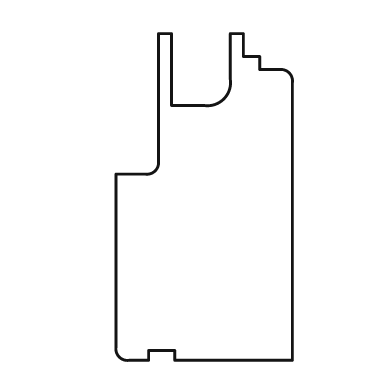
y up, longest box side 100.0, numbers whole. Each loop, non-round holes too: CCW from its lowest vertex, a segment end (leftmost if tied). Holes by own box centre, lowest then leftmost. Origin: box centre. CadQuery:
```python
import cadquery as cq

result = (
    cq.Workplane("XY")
    .moveTo(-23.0, -50.0)
    .lineTo(-17.0, -50.0)
    .lineTo(-17.0, -47.0)
    .lineTo(-9.0, -47.0)
    .lineTo(-9.0, -50.0)
    .lineTo(27.0, -50.0)
    .lineTo(27.0, 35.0)
    .threePointArc((26.0, 38.0), (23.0, 39.0))
    .lineTo(17.0, 39.0)
    .lineTo(17.0, 43.0)
    .lineTo(12.0, 43.0)
    .lineTo(12.0, 50.0)
    .lineTo(8.0, 50.0)
    .lineTo(8.0, 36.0)
    .threePointArc((6.0, 30.0), (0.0, 28.0))
    .lineTo(-10.0, 28.0)
    .lineTo(-10.0, 50.0)
    .lineTo(-14.0, 50.0)
    .lineTo(-14.0, 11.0)
    .threePointArc((-15.0, 8.0), (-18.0, 7.0))
    .lineTo(-27.0, 7.0)
    .lineTo(-27.0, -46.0)
    .threePointArc((-26.0, -49.0), (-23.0, -50.0))
    .close()
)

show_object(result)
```